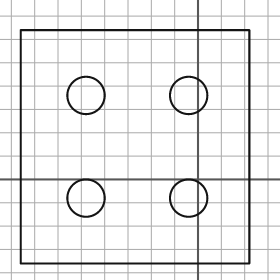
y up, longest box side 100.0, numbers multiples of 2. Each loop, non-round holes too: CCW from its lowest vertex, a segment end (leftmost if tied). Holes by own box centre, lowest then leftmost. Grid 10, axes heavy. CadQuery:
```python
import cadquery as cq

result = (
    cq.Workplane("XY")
    .moveTo(-76.0, -36.0)
    .lineTo(22.0, -36.0)
    .lineTo(22.0, 64.0)
    .lineTo(-76.0, 64.0)
    .close()
    .moveTo(-48.0, -8.0)
    .circle(8.0)
    .moveTo(-4.0, -8.0)
    .circle(8.0)
    .moveTo(-48.0, 36.0)
    .circle(8.0)
    .moveTo(-4.0, 36.0)
    .circle(8.0)
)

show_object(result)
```